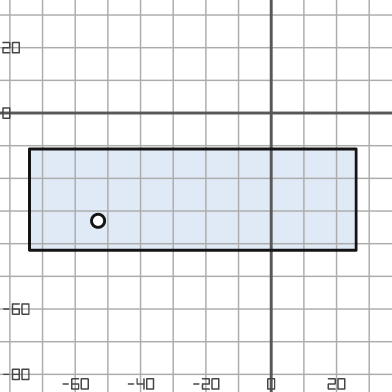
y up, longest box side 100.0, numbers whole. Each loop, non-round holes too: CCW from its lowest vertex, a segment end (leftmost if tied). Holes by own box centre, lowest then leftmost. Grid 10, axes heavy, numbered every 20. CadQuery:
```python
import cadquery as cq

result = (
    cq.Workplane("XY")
    .moveTo(-74.0, -42.0)
    .lineTo(26.0, -42.0)
    .lineTo(26.0, -11.0)
    .lineTo(-74.0, -11.0)
    .close()
    .moveTo(-53.0, -33.0)
    .circle(2.0)
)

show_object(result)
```